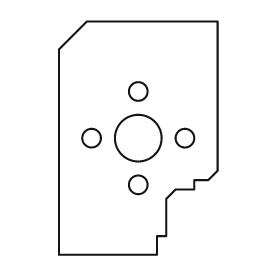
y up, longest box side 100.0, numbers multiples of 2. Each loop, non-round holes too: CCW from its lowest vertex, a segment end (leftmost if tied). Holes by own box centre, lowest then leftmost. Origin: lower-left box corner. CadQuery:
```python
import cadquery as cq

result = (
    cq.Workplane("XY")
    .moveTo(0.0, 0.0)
    .lineTo(42.0, 0.0)
    .lineTo(42.0, 8.0)
    .lineTo(46.0, 8.0)
    .lineTo(46.0, 24.0)
    .lineTo(50.0, 28.0)
    .lineTo(58.0, 28.0)
    .lineTo(58.0, 32.0)
    .lineTo(64.0, 32.0)
    .lineTo(68.0, 36.0)
    .lineTo(68.0, 100.0)
    .lineTo(12.0, 100.0)
    .lineTo(0.0, 88.0)
    .close()
    .moveTo(34.0, 30.0)
    .circle(4.0)
    .moveTo(14.0, 50.0)
    .circle(4.0)
    .moveTo(34.0, 50.0)
    .circle(10.0)
    .moveTo(54.0, 50.0)
    .circle(4.0)
    .moveTo(34.0, 70.0)
    .circle(4.0)
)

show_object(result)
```